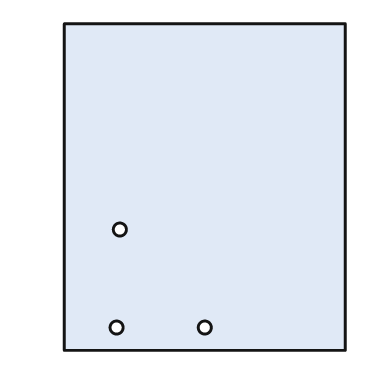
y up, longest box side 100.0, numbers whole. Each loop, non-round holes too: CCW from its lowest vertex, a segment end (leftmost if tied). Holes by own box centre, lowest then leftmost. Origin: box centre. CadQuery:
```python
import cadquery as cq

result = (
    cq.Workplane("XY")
    .moveTo(-43.0, -50.0)
    .lineTo(43.0, -50.0)
    .lineTo(43.0, 50.0)
    .lineTo(-43.0, 50.0)
    .close()
    .moveTo(-27.0, -43.0)
    .circle(2.0)
    .moveTo(0.0, -43.0)
    .circle(2.0)
    .moveTo(-26.0, -13.0)
    .circle(2.0)
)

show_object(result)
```